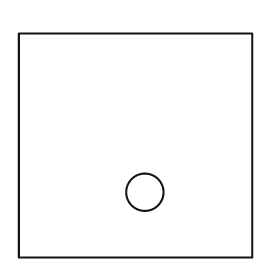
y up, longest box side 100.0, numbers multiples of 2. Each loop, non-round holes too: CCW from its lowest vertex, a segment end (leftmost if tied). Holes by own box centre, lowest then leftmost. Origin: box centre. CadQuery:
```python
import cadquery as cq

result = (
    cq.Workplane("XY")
    .moveTo(-50.0, -48.0)
    .lineTo(50.0, -48.0)
    .lineTo(50.0, 48.0)
    .lineTo(-50.0, 48.0)
    .close()
    .moveTo(4.0, -20.0)
    .circle(8.0)
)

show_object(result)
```